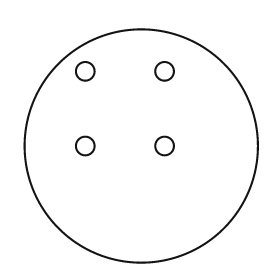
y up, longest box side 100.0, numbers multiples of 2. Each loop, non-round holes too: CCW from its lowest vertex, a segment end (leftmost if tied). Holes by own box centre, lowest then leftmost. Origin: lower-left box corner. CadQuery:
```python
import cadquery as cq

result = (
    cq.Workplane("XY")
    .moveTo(50.0, 50.0)
    .circle(50.0)
    .moveTo(26.0, 50.0)
    .circle(4.0)
    .moveTo(60.0, 50.0)
    .circle(4.0)
    .moveTo(26.0, 82.0)
    .circle(4.0)
    .moveTo(60.0, 82.0)
    .circle(4.0)
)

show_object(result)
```